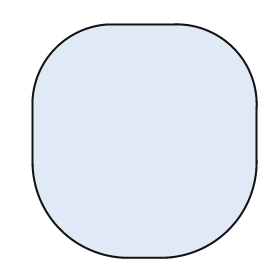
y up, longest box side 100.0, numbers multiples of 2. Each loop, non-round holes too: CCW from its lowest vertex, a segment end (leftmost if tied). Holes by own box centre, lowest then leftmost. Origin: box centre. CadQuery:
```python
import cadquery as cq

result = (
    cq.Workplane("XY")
    .moveTo(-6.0, -50.0)
    .lineTo(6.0, -50.0)
    .threePointArc((36.0, -38.0), (48.0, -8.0))
    .lineTo(48.0, 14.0)
    .threePointArc((38.0, 40.0), (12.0, 50.0))
    .lineTo(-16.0, 50.0)
    .threePointArc((-38.0, 40.0), (-48.0, 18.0))
    .lineTo(-48.0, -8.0)
    .threePointArc((-36.0, -38.0), (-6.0, -50.0))
    .close()
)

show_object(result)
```